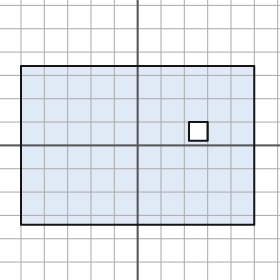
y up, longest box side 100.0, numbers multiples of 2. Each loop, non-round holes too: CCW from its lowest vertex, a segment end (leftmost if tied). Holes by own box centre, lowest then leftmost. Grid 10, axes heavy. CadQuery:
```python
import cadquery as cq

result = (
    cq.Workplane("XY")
    .moveTo(-50.0, -34.0)
    .lineTo(50.0, -34.0)
    .lineTo(50.0, 34.0)
    .lineTo(-50.0, 34.0)
    .close()
    .moveTo(22.0, 2.0)
    .lineTo(30.0, 2.0)
    .lineTo(30.0, 10.0)
    .lineTo(22.0, 10.0)
    .close()
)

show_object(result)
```